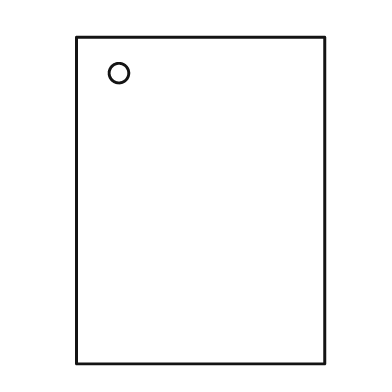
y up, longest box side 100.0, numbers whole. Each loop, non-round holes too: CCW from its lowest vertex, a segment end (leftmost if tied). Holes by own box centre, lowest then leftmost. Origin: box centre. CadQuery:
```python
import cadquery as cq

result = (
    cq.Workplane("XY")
    .moveTo(-38.0, -50.0)
    .lineTo(38.0, -50.0)
    .lineTo(38.0, 50.0)
    .lineTo(-38.0, 50.0)
    .close()
    .moveTo(-25.0, 39.0)
    .circle(3.0)
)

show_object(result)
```